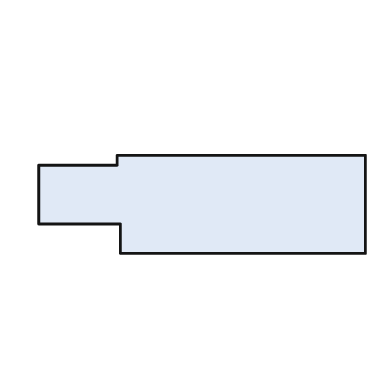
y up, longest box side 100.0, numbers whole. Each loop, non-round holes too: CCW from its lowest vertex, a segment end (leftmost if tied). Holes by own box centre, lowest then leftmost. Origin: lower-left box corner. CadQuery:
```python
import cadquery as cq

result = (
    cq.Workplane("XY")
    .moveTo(25.0, 0.0)
    .lineTo(100.0, 0.0)
    .lineTo(100.0, 30.0)
    .lineTo(24.0, 30.0)
    .lineTo(24.0, 27.0)
    .lineTo(0.0, 27.0)
    .lineTo(0.0, 9.0)
    .lineTo(25.0, 9.0)
    .close()
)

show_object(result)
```